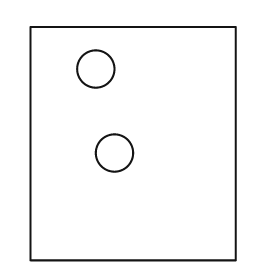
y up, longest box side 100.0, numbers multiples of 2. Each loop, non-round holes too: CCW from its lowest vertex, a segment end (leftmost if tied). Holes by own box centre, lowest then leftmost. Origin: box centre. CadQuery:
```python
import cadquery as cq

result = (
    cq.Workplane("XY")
    .moveTo(-44.0, -50.0)
    .lineTo(44.0, -50.0)
    .lineTo(44.0, 50.0)
    .lineTo(-44.0, 50.0)
    .close()
    .moveTo(-8.0, -4.0)
    .circle(8.0)
    .moveTo(-16.0, 32.0)
    .circle(8.0)
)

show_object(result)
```